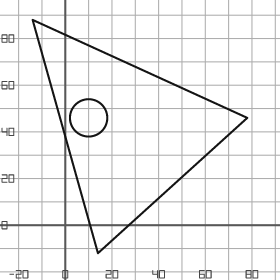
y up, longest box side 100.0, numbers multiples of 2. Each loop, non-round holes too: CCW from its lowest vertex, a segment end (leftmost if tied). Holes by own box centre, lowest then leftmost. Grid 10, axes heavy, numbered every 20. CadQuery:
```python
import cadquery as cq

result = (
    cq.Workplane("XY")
    .moveTo(14.0, -12.0)
    .lineTo(78.0, 46.0)
    .lineTo(-14.0, 88.0)
    .close()
    .moveTo(10.0, 46.0)
    .circle(8.0)
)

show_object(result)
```